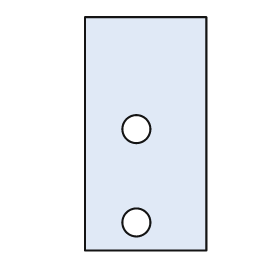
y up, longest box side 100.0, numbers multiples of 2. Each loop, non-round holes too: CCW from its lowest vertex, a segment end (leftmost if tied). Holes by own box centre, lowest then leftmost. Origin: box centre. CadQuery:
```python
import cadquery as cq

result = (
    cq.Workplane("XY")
    .moveTo(-26.0, -50.0)
    .lineTo(26.0, -50.0)
    .lineTo(26.0, 50.0)
    .lineTo(-26.0, 50.0)
    .close()
    .moveTo(-4.0, -38.0)
    .circle(6.0)
    .moveTo(-4.0, 2.0)
    .circle(6.0)
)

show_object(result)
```